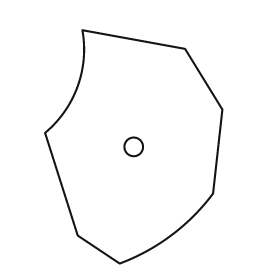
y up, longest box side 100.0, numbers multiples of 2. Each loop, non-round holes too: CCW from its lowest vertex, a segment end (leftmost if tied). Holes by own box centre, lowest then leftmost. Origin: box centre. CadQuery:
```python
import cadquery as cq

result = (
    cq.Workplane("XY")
    .moveTo(-6.0, -50.0)
    .threePointArc((16.0, -38.0), (34.0, -20.0))
    .lineTo(38.0, 16.0)
    .lineTo(22.0, 42.0)
    .lineTo(-22.0, 50.0)
    .threePointArc((-24.0, 26.0), (-38.0, 6.0))
    .lineTo(-24.0, -38.0)
    .close()
    .moveTo(0.0, 0.0)
    .circle(4.0)
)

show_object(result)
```